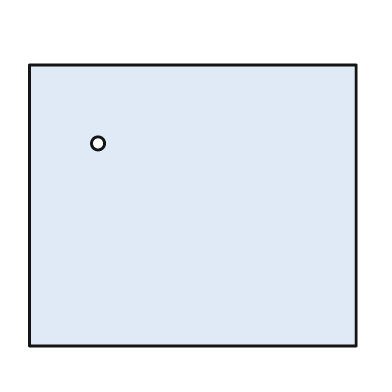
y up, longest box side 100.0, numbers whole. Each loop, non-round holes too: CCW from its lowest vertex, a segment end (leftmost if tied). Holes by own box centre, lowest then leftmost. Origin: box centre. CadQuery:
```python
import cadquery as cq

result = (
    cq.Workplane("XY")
    .moveTo(-50.0, -43.0)
    .lineTo(50.0, -43.0)
    .lineTo(50.0, 43.0)
    .lineTo(-50.0, 43.0)
    .close()
    .moveTo(-29.0, 19.0)
    .circle(2.0)
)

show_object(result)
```